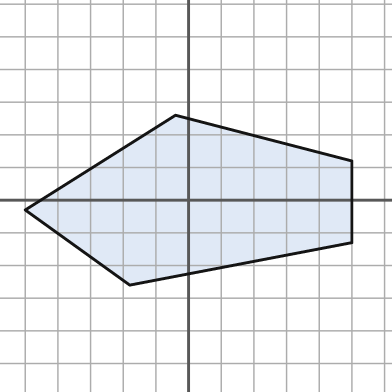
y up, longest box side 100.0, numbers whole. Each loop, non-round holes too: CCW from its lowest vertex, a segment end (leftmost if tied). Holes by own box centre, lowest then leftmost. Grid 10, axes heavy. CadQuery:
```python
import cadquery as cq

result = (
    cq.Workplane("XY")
    .moveTo(-18.0, -26.0)
    .lineTo(50.0, -13.0)
    .lineTo(50.0, 12.0)
    .lineTo(-4.0, 26.0)
    .lineTo(-50.0, -3.0)
    .close()
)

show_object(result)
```